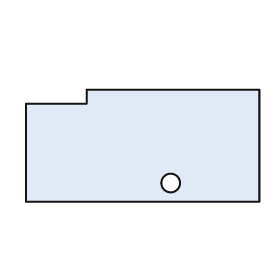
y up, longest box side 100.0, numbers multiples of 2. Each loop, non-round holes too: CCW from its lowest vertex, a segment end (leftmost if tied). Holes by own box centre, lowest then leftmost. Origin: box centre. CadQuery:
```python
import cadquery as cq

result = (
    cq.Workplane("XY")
    .moveTo(-50.0, -24.0)
    .lineTo(50.0, -24.0)
    .lineTo(50.0, 24.0)
    .lineTo(-24.0, 24.0)
    .lineTo(-24.0, 18.0)
    .lineTo(-50.0, 18.0)
    .close()
    .moveTo(12.0, -16.0)
    .circle(4.0)
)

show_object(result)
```